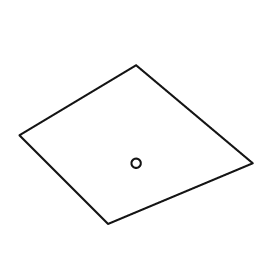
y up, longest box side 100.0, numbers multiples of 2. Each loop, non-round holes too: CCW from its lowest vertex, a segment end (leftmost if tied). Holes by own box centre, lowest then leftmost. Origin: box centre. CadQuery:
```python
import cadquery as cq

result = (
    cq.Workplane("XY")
    .moveTo(-12.0, -34.0)
    .lineTo(50.0, -8.0)
    .lineTo(0.0, 34.0)
    .lineTo(-50.0, 4.0)
    .close()
    .moveTo(0.0, -8.0)
    .circle(2.0)
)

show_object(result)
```